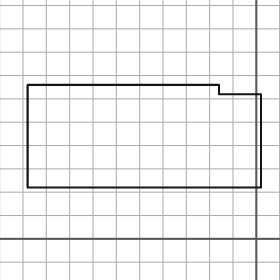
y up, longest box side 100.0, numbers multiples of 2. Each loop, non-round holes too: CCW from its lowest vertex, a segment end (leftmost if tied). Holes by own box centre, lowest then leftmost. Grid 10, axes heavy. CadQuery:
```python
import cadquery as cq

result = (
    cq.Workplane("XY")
    .moveTo(-98.0, 22.0)
    .lineTo(2.0, 22.0)
    .lineTo(2.0, 62.0)
    .lineTo(-16.0, 62.0)
    .lineTo(-16.0, 66.0)
    .lineTo(-98.0, 66.0)
    .close()
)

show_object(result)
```